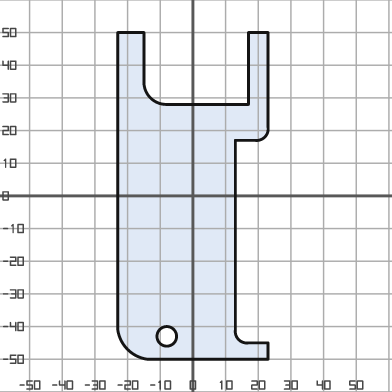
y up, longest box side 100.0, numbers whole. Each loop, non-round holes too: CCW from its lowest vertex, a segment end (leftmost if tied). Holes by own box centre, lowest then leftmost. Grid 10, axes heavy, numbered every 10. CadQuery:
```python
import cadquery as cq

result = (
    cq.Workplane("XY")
    .moveTo(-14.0, -50.0)
    .lineTo(23.0, -50.0)
    .lineTo(23.0, -45.0)
    .lineTo(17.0, -45.0)
    .threePointArc((14.0, -44.0), (13.0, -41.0))
    .lineTo(13.0, 17.0)
    .lineTo(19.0, 17.0)
    .threePointArc((22.0, 18.0), (23.0, 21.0))
    .lineTo(23.0, 50.0)
    .lineTo(17.0, 50.0)
    .lineTo(17.0, 28.0)
    .lineTo(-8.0, 28.0)
    .threePointArc((-13.0, 30.0), (-15.0, 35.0))
    .lineTo(-15.0, 50.0)
    .lineTo(-23.0, 50.0)
    .lineTo(-23.0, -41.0)
    .threePointArc((-20.0, -47.0), (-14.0, -50.0))
    .close()
    .moveTo(-8.0, -43.0)
    .circle(3.0)
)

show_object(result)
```